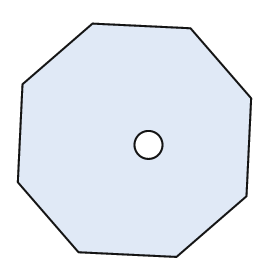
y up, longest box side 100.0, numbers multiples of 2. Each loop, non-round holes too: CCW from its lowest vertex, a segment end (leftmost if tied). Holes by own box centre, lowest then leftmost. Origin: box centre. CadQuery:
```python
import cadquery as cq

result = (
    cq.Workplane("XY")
    .moveTo(18.0, -50.0)
    .lineTo(48.0, -24.0)
    .lineTo(50.0, 18.0)
    .lineTo(24.0, 48.0)
    .lineTo(-18.0, 50.0)
    .lineTo(-48.0, 24.0)
    .lineTo(-50.0, -18.0)
    .lineTo(-24.0, -48.0)
    .close()
    .moveTo(6.0, -2.0)
    .circle(6.0)
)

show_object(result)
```